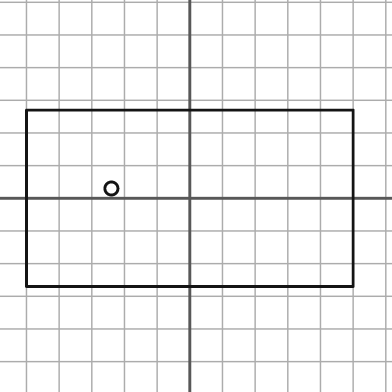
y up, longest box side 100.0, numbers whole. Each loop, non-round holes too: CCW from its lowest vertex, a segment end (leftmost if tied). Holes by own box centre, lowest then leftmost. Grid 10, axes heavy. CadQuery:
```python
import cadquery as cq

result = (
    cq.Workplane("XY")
    .moveTo(-50.0, -27.0)
    .lineTo(50.0, -27.0)
    .lineTo(50.0, 27.0)
    .lineTo(-50.0, 27.0)
    .close()
    .moveTo(-24.0, 3.0)
    .circle(2.0)
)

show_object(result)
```